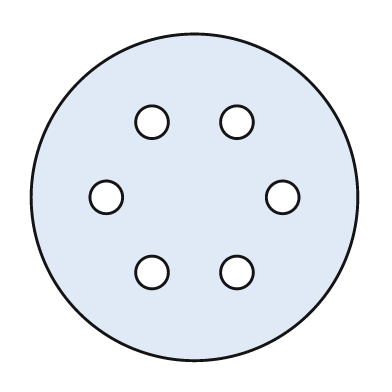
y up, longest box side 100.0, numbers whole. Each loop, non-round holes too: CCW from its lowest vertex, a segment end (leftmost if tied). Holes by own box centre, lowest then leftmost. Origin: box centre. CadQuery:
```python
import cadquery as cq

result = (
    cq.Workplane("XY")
    .moveTo(0.0, 0.0)
    .circle(50.0)
    .moveTo(-13.0, -23.0)
    .circle(5.0)
    .moveTo(13.0, -23.0)
    .circle(5.0)
    .moveTo(-27.0, 0.0)
    .circle(5.0)
    .moveTo(27.0, 0.0)
    .circle(5.0)
    .moveTo(-13.0, 23.0)
    .circle(5.0)
    .moveTo(13.0, 23.0)
    .circle(5.0)
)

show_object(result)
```